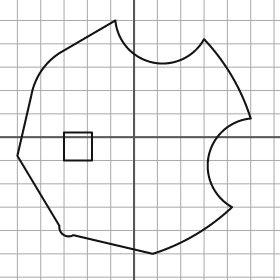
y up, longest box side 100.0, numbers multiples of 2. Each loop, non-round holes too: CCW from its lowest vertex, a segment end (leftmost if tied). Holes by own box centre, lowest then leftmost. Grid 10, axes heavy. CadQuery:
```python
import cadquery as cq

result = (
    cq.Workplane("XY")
    .moveTo(8.0, -50.0)
    .threePointArc((26.0, -42.0), (42.0, -30.0))
    .threePointArc((32.0, -8.0), (50.0, 8.0))
    .threePointArc((42.0, 26.0), (30.0, 42.0))
    .threePointArc((8.0, 32.0), (-8.0, 50.0))
    .lineTo(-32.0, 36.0)
    .threePointArc((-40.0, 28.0), (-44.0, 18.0))
    .lineTo(-50.0, -8.0)
    .lineTo(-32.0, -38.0)
    .threePointArc((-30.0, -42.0), (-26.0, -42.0))
    .close()
    .moveTo(-30.0, -10.0)
    .lineTo(-18.0, -10.0)
    .lineTo(-18.0, 2.0)
    .lineTo(-30.0, 2.0)
    .close()
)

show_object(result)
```